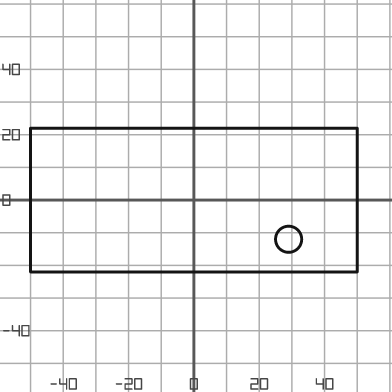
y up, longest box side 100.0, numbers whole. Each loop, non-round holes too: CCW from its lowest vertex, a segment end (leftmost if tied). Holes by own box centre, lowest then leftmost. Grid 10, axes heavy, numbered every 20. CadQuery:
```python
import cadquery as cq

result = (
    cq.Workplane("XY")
    .moveTo(-50.0, -22.0)
    .lineTo(50.0, -22.0)
    .lineTo(50.0, 22.0)
    .lineTo(-50.0, 22.0)
    .close()
    .moveTo(29.0, -12.0)
    .circle(4.0)
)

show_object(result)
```